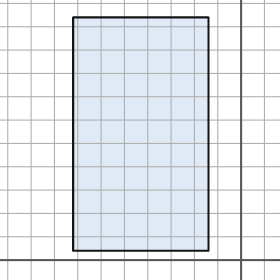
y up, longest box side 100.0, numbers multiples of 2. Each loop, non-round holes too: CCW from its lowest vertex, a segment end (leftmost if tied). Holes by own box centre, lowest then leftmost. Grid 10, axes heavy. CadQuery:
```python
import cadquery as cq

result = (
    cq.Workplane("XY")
    .moveTo(-72.0, 4.0)
    .lineTo(-14.0, 4.0)
    .lineTo(-14.0, 104.0)
    .lineTo(-72.0, 104.0)
    .close()
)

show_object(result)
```